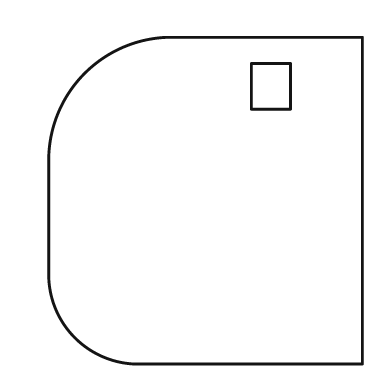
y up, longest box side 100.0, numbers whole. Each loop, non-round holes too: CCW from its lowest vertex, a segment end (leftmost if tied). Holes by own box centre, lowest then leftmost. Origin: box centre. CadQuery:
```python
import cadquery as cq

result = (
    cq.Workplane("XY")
    .moveTo(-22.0, -50.0)
    .lineTo(48.0, -50.0)
    .lineTo(48.0, 50.0)
    .lineTo(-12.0, 50.0)
    .threePointArc((-37.0, 39.0), (-48.0, 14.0))
    .lineTo(-48.0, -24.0)
    .threePointArc((-40.0, -42.0), (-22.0, -50.0))
    .close()
    .moveTo(14.0, 28.0)
    .lineTo(26.0, 28.0)
    .lineTo(26.0, 42.0)
    .lineTo(14.0, 42.0)
    .close()
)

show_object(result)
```